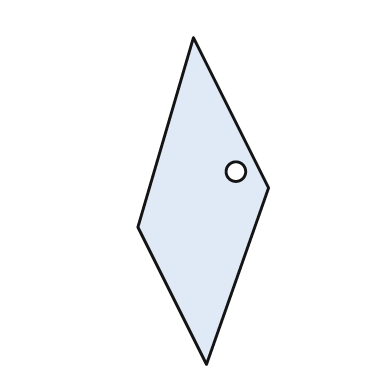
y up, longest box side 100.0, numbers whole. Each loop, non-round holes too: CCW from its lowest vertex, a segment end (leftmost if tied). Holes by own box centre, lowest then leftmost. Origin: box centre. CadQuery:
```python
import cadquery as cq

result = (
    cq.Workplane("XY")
    .moveTo(1.0, -50.0)
    .lineTo(20.0, 4.0)
    .lineTo(-3.0, 50.0)
    .lineTo(-20.0, -8.0)
    .close()
    .moveTo(10.0, 9.0)
    .circle(3.0)
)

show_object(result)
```